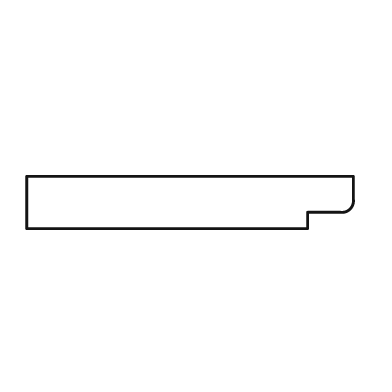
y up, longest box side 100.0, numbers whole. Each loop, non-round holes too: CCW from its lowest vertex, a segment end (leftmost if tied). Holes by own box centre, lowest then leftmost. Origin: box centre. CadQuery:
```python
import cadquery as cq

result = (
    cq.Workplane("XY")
    .moveTo(-50.0, -8.0)
    .lineTo(36.0, -8.0)
    .lineTo(36.0, -3.0)
    .lineTo(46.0, -3.0)
    .threePointArc((49.0, -2.0), (50.0, 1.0))
    .lineTo(50.0, 8.0)
    .lineTo(-50.0, 8.0)
    .close()
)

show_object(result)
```